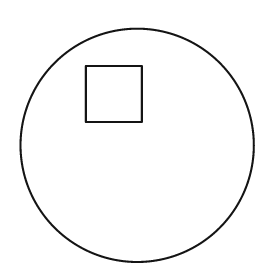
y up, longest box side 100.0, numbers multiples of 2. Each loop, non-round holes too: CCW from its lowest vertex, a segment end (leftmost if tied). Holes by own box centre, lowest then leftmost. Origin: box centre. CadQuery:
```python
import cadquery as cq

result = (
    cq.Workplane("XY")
    .moveTo(0.0, 0.0)
    .circle(50.0)
    .moveTo(-22.0, 10.0)
    .lineTo(2.0, 10.0)
    .lineTo(2.0, 34.0)
    .lineTo(-22.0, 34.0)
    .close()
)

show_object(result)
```